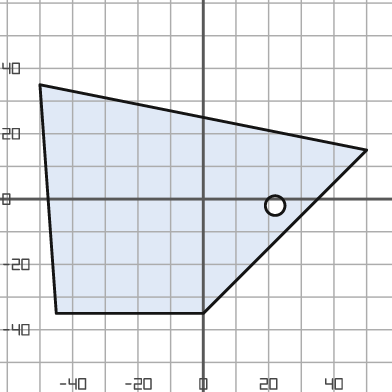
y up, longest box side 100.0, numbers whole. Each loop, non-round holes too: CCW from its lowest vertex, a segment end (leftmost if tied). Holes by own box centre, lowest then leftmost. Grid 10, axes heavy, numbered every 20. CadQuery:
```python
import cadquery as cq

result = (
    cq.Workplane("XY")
    .moveTo(-45.0, -35.0)
    .lineTo(0.0, -35.0)
    .lineTo(50.0, 15.0)
    .lineTo(-50.0, 35.0)
    .close()
    .moveTo(22.0, -2.0)
    .circle(3.0)
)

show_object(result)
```